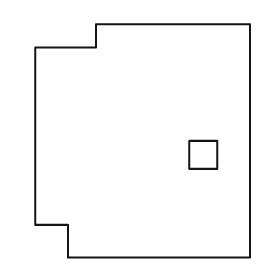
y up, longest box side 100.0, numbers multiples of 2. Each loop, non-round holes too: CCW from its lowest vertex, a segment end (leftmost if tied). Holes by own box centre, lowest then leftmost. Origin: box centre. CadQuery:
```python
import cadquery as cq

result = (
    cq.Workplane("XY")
    .moveTo(-32.0, -50.0)
    .lineTo(46.0, -50.0)
    .lineTo(46.0, 50.0)
    .lineTo(-20.0, 50.0)
    .lineTo(-20.0, 40.0)
    .lineTo(-46.0, 40.0)
    .lineTo(-46.0, -36.0)
    .lineTo(-32.0, -36.0)
    .close()
    .moveTo(20.0, -12.0)
    .lineTo(32.0, -12.0)
    .lineTo(32.0, 0.0)
    .lineTo(20.0, 0.0)
    .close()
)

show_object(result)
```